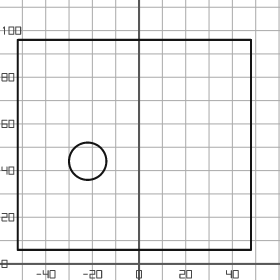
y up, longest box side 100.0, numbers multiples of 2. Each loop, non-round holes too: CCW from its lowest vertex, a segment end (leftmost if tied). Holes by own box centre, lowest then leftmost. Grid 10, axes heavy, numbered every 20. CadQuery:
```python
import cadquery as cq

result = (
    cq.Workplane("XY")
    .moveTo(-52.0, 6.0)
    .lineTo(48.0, 6.0)
    .lineTo(48.0, 96.0)
    .lineTo(-52.0, 96.0)
    .close()
    .moveTo(-22.0, 44.0)
    .circle(8.0)
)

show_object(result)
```